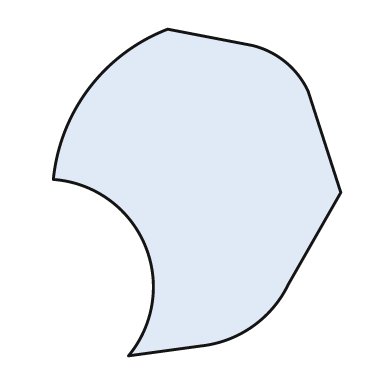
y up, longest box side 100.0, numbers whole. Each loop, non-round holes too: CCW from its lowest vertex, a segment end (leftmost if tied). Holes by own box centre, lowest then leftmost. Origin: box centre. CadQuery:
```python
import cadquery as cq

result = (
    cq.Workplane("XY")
    .moveTo(-21.0, -50.0)
    .lineTo(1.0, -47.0)
    .threePointArc((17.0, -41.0), (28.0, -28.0))
    .lineTo(44.0, 0.0)
    .lineTo(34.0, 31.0)
    .threePointArc((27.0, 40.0), (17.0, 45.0))
    .lineTo(-9.0, 50.0)
    .threePointArc((-33.0, 32.0), (-44.0, 4.0))
    .threePointArc((-16.0, -16.0), (-21.0, -50.0))
    .close()
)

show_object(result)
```